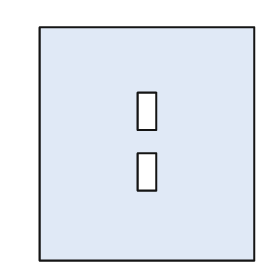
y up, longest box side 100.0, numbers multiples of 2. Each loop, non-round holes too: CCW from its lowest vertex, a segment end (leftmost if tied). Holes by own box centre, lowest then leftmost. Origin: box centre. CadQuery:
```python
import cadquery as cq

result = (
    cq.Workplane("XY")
    .moveTo(-46.0, -50.0)
    .lineTo(46.0, -50.0)
    .lineTo(46.0, 50.0)
    .lineTo(-46.0, 50.0)
    .close()
    .moveTo(-4.0, -20.0)
    .lineTo(4.0, -20.0)
    .lineTo(4.0, -4.0)
    .lineTo(-4.0, -4.0)
    .close()
    .moveTo(-4.0, 6.0)
    .lineTo(4.0, 6.0)
    .lineTo(4.0, 22.0)
    .lineTo(-4.0, 22.0)
    .close()
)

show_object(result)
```